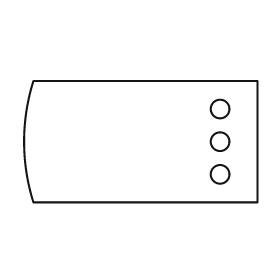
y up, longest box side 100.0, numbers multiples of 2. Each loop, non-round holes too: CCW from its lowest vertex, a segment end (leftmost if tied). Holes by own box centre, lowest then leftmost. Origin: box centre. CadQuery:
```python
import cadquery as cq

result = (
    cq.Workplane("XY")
    .moveTo(-46.0, -26.0)
    .lineTo(50.0, -26.0)
    .lineTo(50.0, 26.0)
    .lineTo(-46.0, 26.0)
    .threePointArc((-50.0, 0.0), (-46.0, -26.0))
    .close()
    .moveTo(34.0, -14.0)
    .circle(4.0)
    .moveTo(34.0, 0.0)
    .circle(4.0)
    .moveTo(34.0, 14.0)
    .circle(4.0)
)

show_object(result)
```